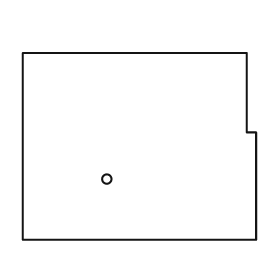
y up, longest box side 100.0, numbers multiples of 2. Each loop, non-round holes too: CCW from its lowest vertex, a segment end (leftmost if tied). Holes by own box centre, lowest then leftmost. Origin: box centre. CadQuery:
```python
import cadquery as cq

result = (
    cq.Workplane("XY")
    .moveTo(-50.0, -40.0)
    .lineTo(50.0, -40.0)
    .lineTo(50.0, 6.0)
    .lineTo(46.0, 6.0)
    .lineTo(46.0, 40.0)
    .lineTo(-50.0, 40.0)
    .close()
    .moveTo(-14.0, -14.0)
    .circle(2.0)
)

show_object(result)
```